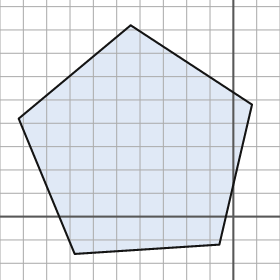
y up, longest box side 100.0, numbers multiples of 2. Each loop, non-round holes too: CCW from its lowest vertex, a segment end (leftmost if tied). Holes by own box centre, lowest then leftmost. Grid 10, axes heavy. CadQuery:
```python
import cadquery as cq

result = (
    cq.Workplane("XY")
    .moveTo(-68.0, -16.0)
    .lineTo(-6.0, -12.0)
    .lineTo(8.0, 48.0)
    .lineTo(-44.0, 82.0)
    .lineTo(-92.0, 42.0)
    .close()
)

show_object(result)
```